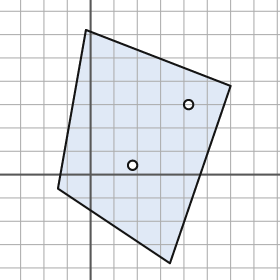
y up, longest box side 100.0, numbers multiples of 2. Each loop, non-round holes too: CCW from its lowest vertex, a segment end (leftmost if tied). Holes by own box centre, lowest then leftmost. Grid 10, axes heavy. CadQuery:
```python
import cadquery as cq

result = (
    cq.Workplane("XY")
    .moveTo(34.0, -38.0)
    .lineTo(60.0, 38.0)
    .lineTo(-2.0, 62.0)
    .lineTo(-14.0, -6.0)
    .close()
    .moveTo(18.0, 4.0)
    .circle(2.0)
    .moveTo(42.0, 30.0)
    .circle(2.0)
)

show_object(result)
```